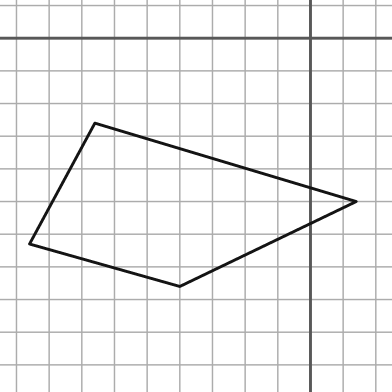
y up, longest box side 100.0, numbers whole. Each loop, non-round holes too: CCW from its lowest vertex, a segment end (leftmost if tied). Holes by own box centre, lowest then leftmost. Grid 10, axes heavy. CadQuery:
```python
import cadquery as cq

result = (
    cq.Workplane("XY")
    .moveTo(-40.0, -76.0)
    .lineTo(14.0, -50.0)
    .lineTo(-66.0, -26.0)
    .lineTo(-86.0, -63.0)
    .close()
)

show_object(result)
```